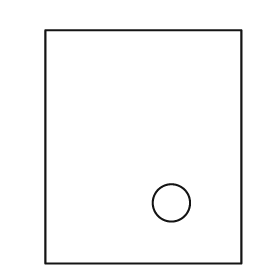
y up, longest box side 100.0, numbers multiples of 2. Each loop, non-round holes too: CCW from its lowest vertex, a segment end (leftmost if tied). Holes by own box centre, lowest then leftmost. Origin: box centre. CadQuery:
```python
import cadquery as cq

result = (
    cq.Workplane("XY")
    .moveTo(-42.0, -50.0)
    .lineTo(42.0, -50.0)
    .lineTo(42.0, 50.0)
    .lineTo(-42.0, 50.0)
    .close()
    .moveTo(12.0, -24.0)
    .circle(8.0)
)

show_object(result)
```